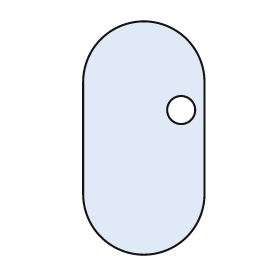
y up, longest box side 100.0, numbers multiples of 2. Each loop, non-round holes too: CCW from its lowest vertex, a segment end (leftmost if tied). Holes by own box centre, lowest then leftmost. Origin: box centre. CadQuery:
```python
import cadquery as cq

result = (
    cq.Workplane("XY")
    .moveTo(-26.0, -24.0)
    .threePointArc((0.0, -50.0), (26.0, -24.0))
    .lineTo(26.0, 24.0)
    .threePointArc((0.0, 50.0), (-26.0, 24.0))
    .close()
    .moveTo(16.0, 12.0)
    .circle(6.0)
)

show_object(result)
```